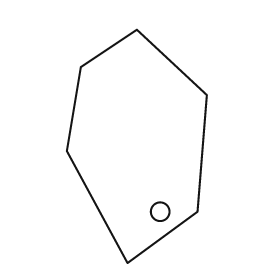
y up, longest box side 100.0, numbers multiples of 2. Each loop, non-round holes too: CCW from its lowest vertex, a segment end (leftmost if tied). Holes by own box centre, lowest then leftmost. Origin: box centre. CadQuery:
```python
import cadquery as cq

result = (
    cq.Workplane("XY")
    .moveTo(-4.0, -50.0)
    .lineTo(26.0, -28.0)
    .lineTo(30.0, 22.0)
    .lineTo(0.0, 50.0)
    .lineTo(-24.0, 34.0)
    .lineTo(-30.0, -2.0)
    .close()
    .moveTo(10.0, -28.0)
    .circle(4.0)
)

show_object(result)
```